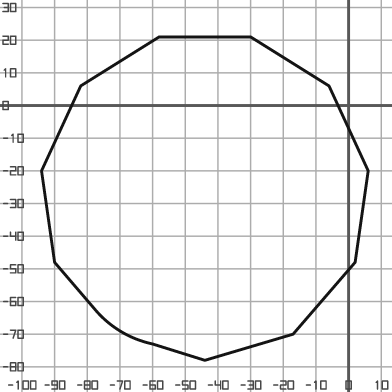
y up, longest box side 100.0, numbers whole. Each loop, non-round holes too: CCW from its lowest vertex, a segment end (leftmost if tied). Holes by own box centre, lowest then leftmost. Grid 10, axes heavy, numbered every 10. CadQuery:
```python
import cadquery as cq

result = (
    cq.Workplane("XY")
    .moveTo(-44.0, -78.0)
    .lineTo(-17.0, -70.0)
    .lineTo(2.0, -48.0)
    .lineTo(6.0, -20.0)
    .lineTo(-6.0, 6.0)
    .lineTo(-30.0, 21.0)
    .lineTo(-58.0, 21.0)
    .lineTo(-82.0, 6.0)
    .lineTo(-94.0, -20.0)
    .lineTo(-90.0, -48.0)
    .lineTo(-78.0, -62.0)
    .threePointArc((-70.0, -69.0), (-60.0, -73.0))
    .close()
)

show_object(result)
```